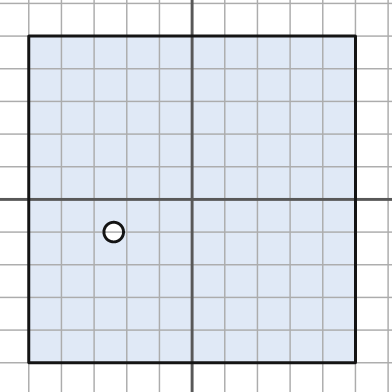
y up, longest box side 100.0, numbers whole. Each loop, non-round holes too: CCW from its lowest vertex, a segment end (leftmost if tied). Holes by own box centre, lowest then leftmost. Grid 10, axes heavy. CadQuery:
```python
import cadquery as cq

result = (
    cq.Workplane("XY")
    .moveTo(-50.0, -50.0)
    .lineTo(50.0, -50.0)
    .lineTo(50.0, 50.0)
    .lineTo(-50.0, 50.0)
    .close()
    .moveTo(-24.0, -10.0)
    .circle(3.0)
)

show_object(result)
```